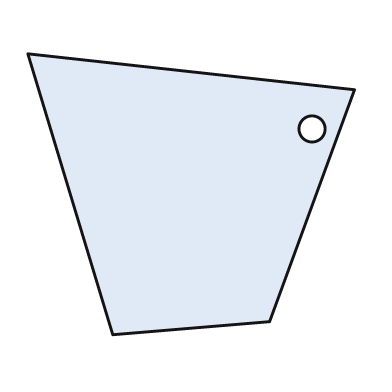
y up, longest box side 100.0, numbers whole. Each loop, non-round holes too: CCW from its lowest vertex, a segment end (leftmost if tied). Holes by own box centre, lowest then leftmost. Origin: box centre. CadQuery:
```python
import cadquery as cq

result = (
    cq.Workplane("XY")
    .moveTo(-24.0, -43.0)
    .lineTo(24.0, -39.0)
    .lineTo(50.0, 32.0)
    .lineTo(-50.0, 43.0)
    .close()
    .moveTo(37.0, 20.0)
    .circle(4.0)
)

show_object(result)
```